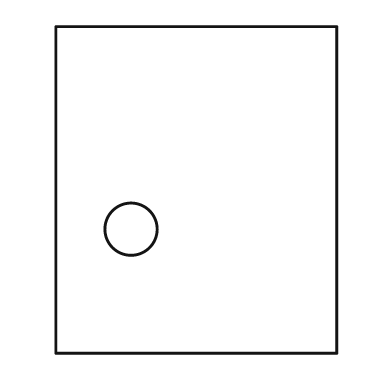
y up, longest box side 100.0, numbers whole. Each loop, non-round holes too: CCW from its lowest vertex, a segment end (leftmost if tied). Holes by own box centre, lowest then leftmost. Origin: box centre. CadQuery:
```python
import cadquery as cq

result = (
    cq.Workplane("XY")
    .moveTo(-43.0, -50.0)
    .lineTo(43.0, -50.0)
    .lineTo(43.0, 50.0)
    .lineTo(-43.0, 50.0)
    .close()
    .moveTo(-20.0, -12.0)
    .circle(8.0)
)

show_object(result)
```